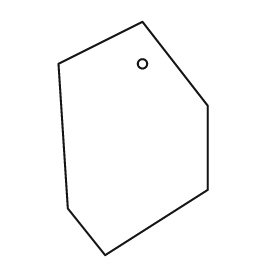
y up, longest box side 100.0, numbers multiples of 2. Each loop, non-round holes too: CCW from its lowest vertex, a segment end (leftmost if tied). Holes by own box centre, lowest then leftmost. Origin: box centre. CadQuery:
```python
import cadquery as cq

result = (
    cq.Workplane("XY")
    .moveTo(-12.0, -50.0)
    .lineTo(32.0, -22.0)
    .lineTo(32.0, 14.0)
    .lineTo(4.0, 50.0)
    .lineTo(-32.0, 32.0)
    .lineTo(-28.0, -30.0)
    .close()
    .moveTo(4.0, 32.0)
    .circle(2.0)
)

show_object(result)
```